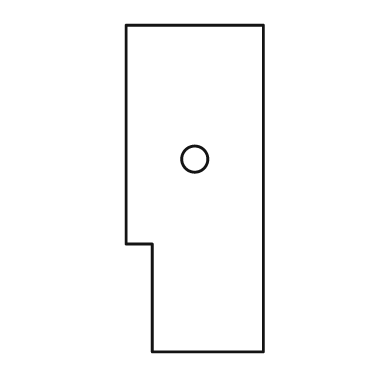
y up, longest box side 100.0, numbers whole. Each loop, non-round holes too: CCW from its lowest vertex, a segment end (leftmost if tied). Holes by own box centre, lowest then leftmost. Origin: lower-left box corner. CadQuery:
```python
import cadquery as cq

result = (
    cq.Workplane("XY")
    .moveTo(8.0, 0.0)
    .lineTo(42.0, 0.0)
    .lineTo(42.0, 100.0)
    .lineTo(0.0, 100.0)
    .lineTo(0.0, 33.0)
    .lineTo(8.0, 33.0)
    .close()
    .moveTo(21.0, 59.0)
    .circle(4.0)
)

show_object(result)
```